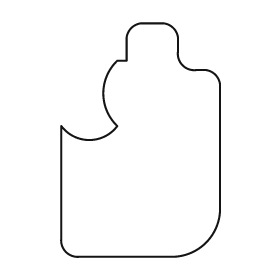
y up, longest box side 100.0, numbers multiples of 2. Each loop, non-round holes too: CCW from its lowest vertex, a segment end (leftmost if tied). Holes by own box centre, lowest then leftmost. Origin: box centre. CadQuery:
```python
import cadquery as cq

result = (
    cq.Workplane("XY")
    .moveTo(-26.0, -50.0)
    .lineTo(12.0, -50.0)
    .threePointArc((28.0, -44.0), (34.0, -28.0))
    .lineTo(34.0, 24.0)
    .threePointArc((32.0, 28.0), (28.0, 30.0))
    .lineTo(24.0, 30.0)
    .threePointArc((18.0, 32.0), (16.0, 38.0))
    .lineTo(16.0, 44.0)
    .threePointArc((14.0, 48.0), (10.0, 50.0))
    .lineTo(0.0, 50.0)
    .threePointArc((-4.0, 48.0), (-6.0, 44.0))
    .lineTo(-6.0, 34.0)
    .lineTo(-10.0, 34.0)
    .threePointArc((-16.0, 20.0), (-10.0, 6.0))
    .threePointArc((-22.0, 0.0), (-34.0, 6.0))
    .lineTo(-34.0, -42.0)
    .threePointArc((-32.0, -48.0), (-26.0, -50.0))
    .close()
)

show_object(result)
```